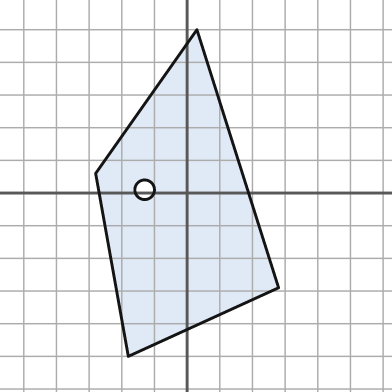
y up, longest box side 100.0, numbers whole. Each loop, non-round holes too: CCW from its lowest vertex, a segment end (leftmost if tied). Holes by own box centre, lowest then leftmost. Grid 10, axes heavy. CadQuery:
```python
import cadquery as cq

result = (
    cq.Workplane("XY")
    .moveTo(-18.0, -50.0)
    .lineTo(28.0, -29.0)
    .lineTo(3.0, 50.0)
    .lineTo(-28.0, 6.0)
    .close()
    .moveTo(-13.0, 1.0)
    .circle(3.0)
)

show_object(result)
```